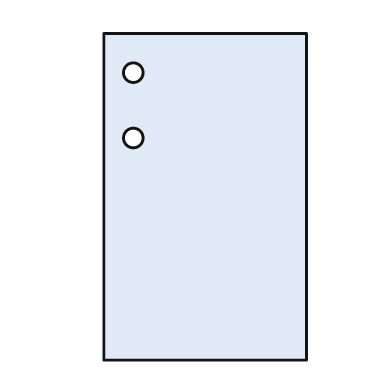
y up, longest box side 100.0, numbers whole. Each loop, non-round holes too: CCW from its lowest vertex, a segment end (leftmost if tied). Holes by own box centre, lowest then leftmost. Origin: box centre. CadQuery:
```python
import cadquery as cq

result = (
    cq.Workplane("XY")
    .moveTo(-31.0, -50.0)
    .lineTo(31.0, -50.0)
    .lineTo(31.0, 50.0)
    .lineTo(-31.0, 50.0)
    .close()
    .moveTo(-22.0, 18.0)
    .circle(3.0)
    .moveTo(-22.0, 38.0)
    .circle(3.0)
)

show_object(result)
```